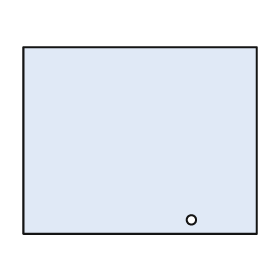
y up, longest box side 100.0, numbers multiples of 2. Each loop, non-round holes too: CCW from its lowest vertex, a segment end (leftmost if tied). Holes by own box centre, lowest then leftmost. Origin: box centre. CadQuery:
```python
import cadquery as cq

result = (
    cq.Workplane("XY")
    .moveTo(-50.0, -40.0)
    .lineTo(50.0, -40.0)
    .lineTo(50.0, 40.0)
    .lineTo(-50.0, 40.0)
    .close()
    .moveTo(22.0, -34.0)
    .circle(2.0)
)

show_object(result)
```